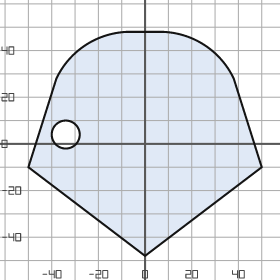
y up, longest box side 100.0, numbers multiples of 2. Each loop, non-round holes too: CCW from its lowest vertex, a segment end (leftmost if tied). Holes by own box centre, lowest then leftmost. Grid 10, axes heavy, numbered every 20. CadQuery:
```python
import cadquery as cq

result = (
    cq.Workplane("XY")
    .moveTo(0.0, -48.0)
    .lineTo(50.0, -10.0)
    .lineTo(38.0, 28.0)
    .threePointArc((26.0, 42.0), (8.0, 48.0))
    .lineTo(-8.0, 48.0)
    .threePointArc((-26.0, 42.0), (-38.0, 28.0))
    .lineTo(-50.0, -10.0)
    .close()
    .moveTo(-34.0, 4.0)
    .circle(6.0)
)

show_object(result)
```